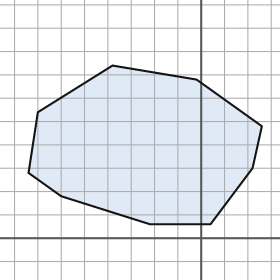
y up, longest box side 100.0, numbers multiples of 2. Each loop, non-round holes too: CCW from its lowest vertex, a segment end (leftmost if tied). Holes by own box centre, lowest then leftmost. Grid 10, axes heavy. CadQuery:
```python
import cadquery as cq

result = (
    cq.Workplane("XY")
    .moveTo(-22.0, 6.0)
    .lineTo(4.0, 6.0)
    .lineTo(22.0, 30.0)
    .lineTo(26.0, 48.0)
    .lineTo(-2.0, 68.0)
    .lineTo(-38.0, 74.0)
    .lineTo(-70.0, 54.0)
    .lineTo(-74.0, 28.0)
    .lineTo(-60.0, 18.0)
    .close()
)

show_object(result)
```